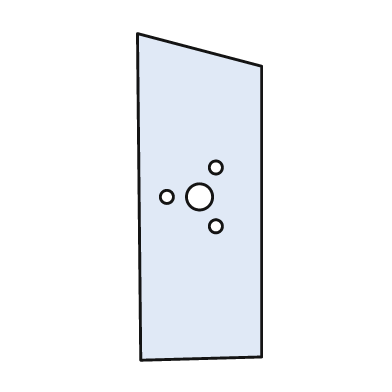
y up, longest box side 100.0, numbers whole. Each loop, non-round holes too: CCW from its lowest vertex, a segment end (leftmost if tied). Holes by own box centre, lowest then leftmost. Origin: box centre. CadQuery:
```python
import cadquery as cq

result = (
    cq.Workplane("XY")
    .moveTo(-18.0, -50.0)
    .lineTo(19.0, -49.0)
    .lineTo(19.0, 40.0)
    .lineTo(-19.0, 50.0)
    .close()
    .moveTo(5.0, -9.0)
    .circle(2.0)
    .moveTo(-10.0, 0.0)
    .circle(2.0)
    .moveTo(0.0, 0.0)
    .circle(4.0)
    .moveTo(5.0, 9.0)
    .circle(2.0)
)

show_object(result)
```